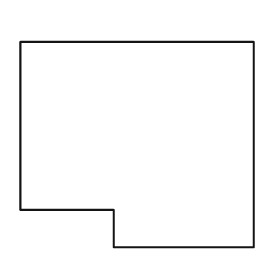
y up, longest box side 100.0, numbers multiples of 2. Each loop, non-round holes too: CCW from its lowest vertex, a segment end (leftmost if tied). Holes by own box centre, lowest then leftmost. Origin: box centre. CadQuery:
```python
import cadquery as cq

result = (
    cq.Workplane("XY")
    .moveTo(-10.0, -44.0)
    .lineTo(50.0, -44.0)
    .lineTo(50.0, 44.0)
    .lineTo(-50.0, 44.0)
    .lineTo(-50.0, -28.0)
    .lineTo(-10.0, -28.0)
    .close()
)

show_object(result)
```